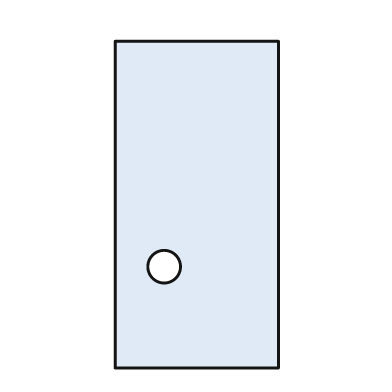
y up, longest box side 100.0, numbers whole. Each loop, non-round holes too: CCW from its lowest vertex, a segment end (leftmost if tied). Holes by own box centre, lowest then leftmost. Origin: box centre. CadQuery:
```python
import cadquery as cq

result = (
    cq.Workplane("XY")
    .moveTo(-25.0, -50.0)
    .lineTo(25.0, -50.0)
    .lineTo(25.0, 50.0)
    .lineTo(-25.0, 50.0)
    .close()
    .moveTo(-10.0, -19.0)
    .circle(5.0)
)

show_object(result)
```